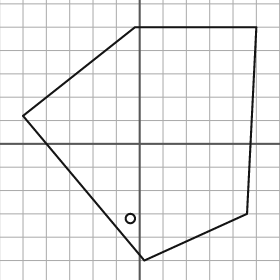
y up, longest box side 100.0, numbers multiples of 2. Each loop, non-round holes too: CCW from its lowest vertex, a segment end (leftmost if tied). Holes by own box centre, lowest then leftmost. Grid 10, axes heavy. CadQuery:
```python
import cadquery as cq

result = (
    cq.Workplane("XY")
    .moveTo(2.0, -50.0)
    .lineTo(46.0, -30.0)
    .lineTo(50.0, 50.0)
    .lineTo(-2.0, 50.0)
    .lineTo(-50.0, 12.0)
    .close()
    .moveTo(-4.0, -32.0)
    .circle(2.0)
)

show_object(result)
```